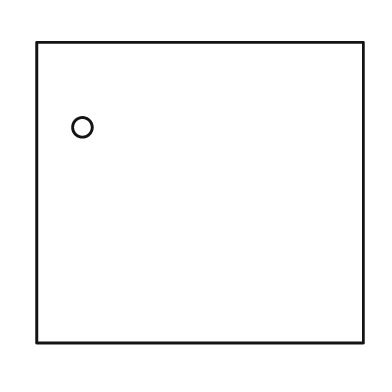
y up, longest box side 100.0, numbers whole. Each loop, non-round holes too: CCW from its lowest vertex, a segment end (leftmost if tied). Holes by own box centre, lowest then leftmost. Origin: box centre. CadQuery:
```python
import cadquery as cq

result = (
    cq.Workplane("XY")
    .moveTo(-50.0, -46.0)
    .lineTo(50.0, -46.0)
    .lineTo(50.0, 46.0)
    .lineTo(-50.0, 46.0)
    .close()
    .moveTo(-36.0, 20.0)
    .circle(3.0)
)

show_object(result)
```